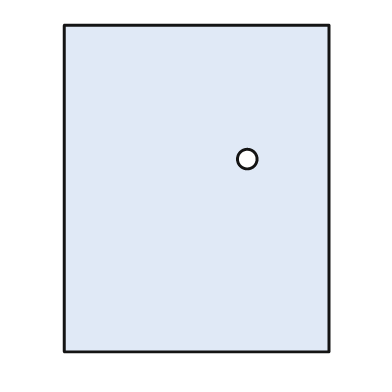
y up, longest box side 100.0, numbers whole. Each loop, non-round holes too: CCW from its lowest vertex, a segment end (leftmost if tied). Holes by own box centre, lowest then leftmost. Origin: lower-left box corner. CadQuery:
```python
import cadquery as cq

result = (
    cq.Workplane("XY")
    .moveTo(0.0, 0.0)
    .lineTo(81.0, 0.0)
    .lineTo(81.0, 100.0)
    .lineTo(0.0, 100.0)
    .close()
    .moveTo(56.0, 59.0)
    .circle(3.0)
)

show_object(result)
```